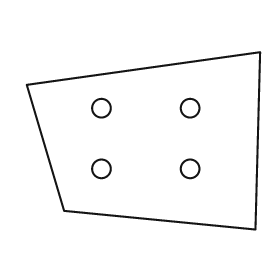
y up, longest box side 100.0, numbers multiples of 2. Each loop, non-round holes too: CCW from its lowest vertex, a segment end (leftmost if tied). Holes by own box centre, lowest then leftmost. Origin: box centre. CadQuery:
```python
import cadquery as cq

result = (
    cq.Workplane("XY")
    .moveTo(48.0, -38.0)
    .lineTo(50.0, 38.0)
    .lineTo(-50.0, 24.0)
    .lineTo(-34.0, -30.0)
    .close()
    .moveTo(-18.0, -12.0)
    .circle(4.0)
    .moveTo(20.0, -12.0)
    .circle(4.0)
    .moveTo(-18.0, 14.0)
    .circle(4.0)
    .moveTo(20.0, 14.0)
    .circle(4.0)
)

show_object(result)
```